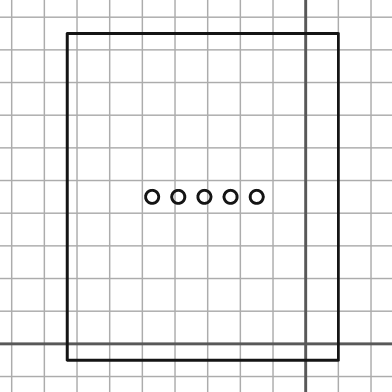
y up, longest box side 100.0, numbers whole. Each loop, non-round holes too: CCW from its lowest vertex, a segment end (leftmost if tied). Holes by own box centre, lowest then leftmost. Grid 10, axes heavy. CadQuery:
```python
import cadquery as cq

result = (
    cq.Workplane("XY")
    .moveTo(-73.0, -5.0)
    .lineTo(10.0, -5.0)
    .lineTo(10.0, 95.0)
    .lineTo(-73.0, 95.0)
    .close()
    .moveTo(-47.0, 45.0)
    .circle(2.0)
    .moveTo(-39.0, 45.0)
    .circle(2.0)
    .moveTo(-31.0, 45.0)
    .circle(2.0)
    .moveTo(-23.0, 45.0)
    .circle(2.0)
    .moveTo(-15.0, 45.0)
    .circle(2.0)
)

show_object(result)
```